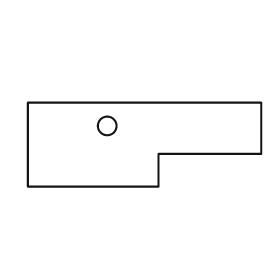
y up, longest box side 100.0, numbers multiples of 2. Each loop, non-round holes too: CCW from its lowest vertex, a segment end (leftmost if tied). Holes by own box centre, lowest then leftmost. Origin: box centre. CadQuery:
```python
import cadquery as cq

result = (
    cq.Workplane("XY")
    .moveTo(-50.0, -18.0)
    .lineTo(6.0, -18.0)
    .lineTo(6.0, -4.0)
    .lineTo(50.0, -4.0)
    .lineTo(50.0, 18.0)
    .lineTo(-50.0, 18.0)
    .close()
    .moveTo(-16.0, 8.0)
    .circle(4.0)
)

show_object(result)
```